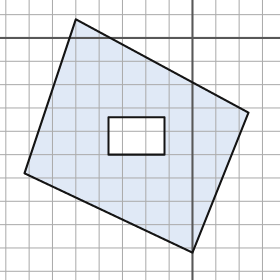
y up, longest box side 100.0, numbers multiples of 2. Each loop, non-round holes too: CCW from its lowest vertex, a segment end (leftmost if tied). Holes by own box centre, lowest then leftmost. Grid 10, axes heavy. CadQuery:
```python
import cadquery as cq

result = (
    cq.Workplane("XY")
    .moveTo(0.0, -92.0)
    .lineTo(24.0, -32.0)
    .lineTo(-50.0, 8.0)
    .lineTo(-72.0, -58.0)
    .close()
    .moveTo(-36.0, -50.0)
    .lineTo(-12.0, -50.0)
    .lineTo(-12.0, -34.0)
    .lineTo(-36.0, -34.0)
    .close()
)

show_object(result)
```